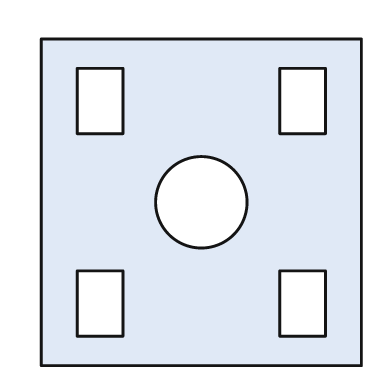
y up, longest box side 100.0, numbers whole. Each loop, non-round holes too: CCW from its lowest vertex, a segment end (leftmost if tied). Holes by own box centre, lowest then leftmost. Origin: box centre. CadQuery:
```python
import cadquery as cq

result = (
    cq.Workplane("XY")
    .moveTo(-49.0, -50.0)
    .lineTo(49.0, -50.0)
    .lineTo(49.0, 50.0)
    .lineTo(-49.0, 50.0)
    .close()
    .moveTo(-38.0, -41.0)
    .lineTo(-24.0, -41.0)
    .lineTo(-24.0, -21.0)
    .lineTo(-38.0, -21.0)
    .close()
    .moveTo(24.0, -41.0)
    .lineTo(38.0, -41.0)
    .lineTo(38.0, -21.0)
    .lineTo(24.0, -21.0)
    .close()
    .moveTo(0.0, 0.0)
    .circle(14.0)
    .moveTo(-38.0, 21.0)
    .lineTo(-24.0, 21.0)
    .lineTo(-24.0, 41.0)
    .lineTo(-38.0, 41.0)
    .close()
    .moveTo(24.0, 21.0)
    .lineTo(38.0, 21.0)
    .lineTo(38.0, 41.0)
    .lineTo(24.0, 41.0)
    .close()
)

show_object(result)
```